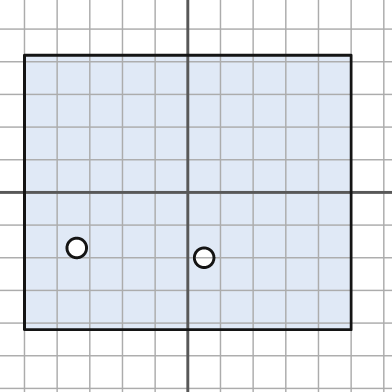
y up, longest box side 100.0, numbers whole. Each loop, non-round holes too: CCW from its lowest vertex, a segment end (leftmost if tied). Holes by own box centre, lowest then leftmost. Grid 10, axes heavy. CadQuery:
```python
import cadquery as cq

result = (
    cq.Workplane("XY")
    .moveTo(-50.0, -42.0)
    .lineTo(50.0, -42.0)
    .lineTo(50.0, 42.0)
    .lineTo(-50.0, 42.0)
    .close()
    .moveTo(5.0, -20.0)
    .circle(3.0)
    .moveTo(-34.0, -17.0)
    .circle(3.0)
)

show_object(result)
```